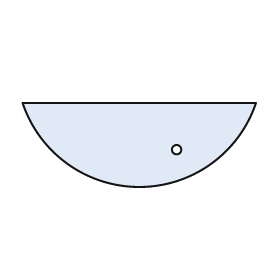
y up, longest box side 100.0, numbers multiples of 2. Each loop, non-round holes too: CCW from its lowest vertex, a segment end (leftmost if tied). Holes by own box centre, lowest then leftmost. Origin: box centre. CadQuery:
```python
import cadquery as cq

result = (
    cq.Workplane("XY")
    .moveTo(-50.0, 18.0)
    .threePointArc((0.0, -18.0), (50.0, 18.0))
    .close()
    .moveTo(16.0, -2.0)
    .circle(2.0)
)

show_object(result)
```